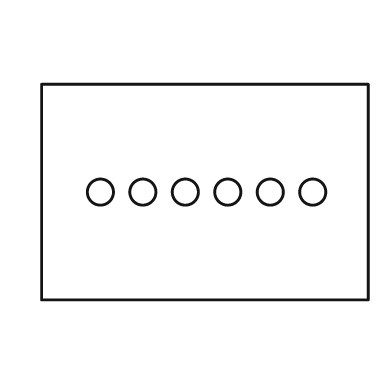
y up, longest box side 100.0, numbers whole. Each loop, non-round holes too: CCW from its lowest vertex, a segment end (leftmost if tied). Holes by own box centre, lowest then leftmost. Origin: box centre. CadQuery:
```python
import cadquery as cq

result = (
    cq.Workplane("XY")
    .moveTo(-50.0, -33.0)
    .lineTo(50.0, -33.0)
    .lineTo(50.0, 33.0)
    .lineTo(-50.0, 33.0)
    .close()
    .moveTo(-32.0, 0.0)
    .circle(4.0)
    .moveTo(-19.0, 0.0)
    .circle(4.0)
    .moveTo(-6.0, 0.0)
    .circle(4.0)
    .moveTo(7.0, 0.0)
    .circle(4.0)
    .moveTo(20.0, 0.0)
    .circle(4.0)
    .moveTo(33.0, 0.0)
    .circle(4.0)
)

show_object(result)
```